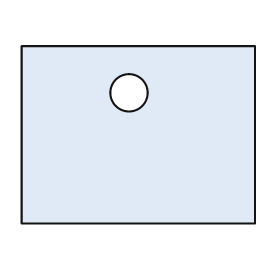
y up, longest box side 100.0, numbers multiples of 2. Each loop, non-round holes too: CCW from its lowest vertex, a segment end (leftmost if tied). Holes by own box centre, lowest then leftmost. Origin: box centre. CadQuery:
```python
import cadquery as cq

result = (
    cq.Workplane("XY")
    .moveTo(-50.0, -38.0)
    .lineTo(50.0, -38.0)
    .lineTo(50.0, 38.0)
    .lineTo(-50.0, 38.0)
    .close()
    .moveTo(-4.0, 18.0)
    .circle(8.0)
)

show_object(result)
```